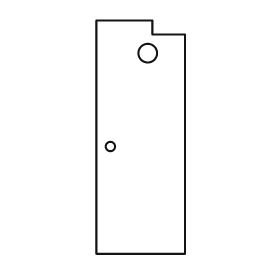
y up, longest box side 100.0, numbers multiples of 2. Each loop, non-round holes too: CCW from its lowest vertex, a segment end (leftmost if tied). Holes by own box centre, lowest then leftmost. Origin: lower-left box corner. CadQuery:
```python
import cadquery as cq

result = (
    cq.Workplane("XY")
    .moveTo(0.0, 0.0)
    .lineTo(38.0, 0.0)
    .lineTo(38.0, 94.0)
    .lineTo(24.0, 94.0)
    .lineTo(24.0, 100.0)
    .lineTo(0.0, 100.0)
    .close()
    .moveTo(6.0, 46.0)
    .circle(2.0)
    .moveTo(22.0, 86.0)
    .circle(4.0)
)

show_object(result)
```